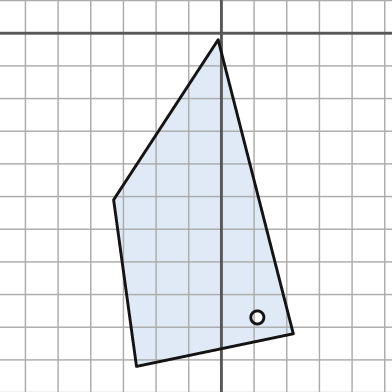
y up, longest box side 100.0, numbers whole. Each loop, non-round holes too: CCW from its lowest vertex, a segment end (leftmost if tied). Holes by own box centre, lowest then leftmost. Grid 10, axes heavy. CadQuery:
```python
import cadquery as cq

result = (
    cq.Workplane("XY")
    .moveTo(-26.0, -102.0)
    .lineTo(22.0, -92.0)
    .lineTo(-1.0, -2.0)
    .lineTo(-33.0, -51.0)
    .close()
    .moveTo(11.0, -87.0)
    .circle(2.0)
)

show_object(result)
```